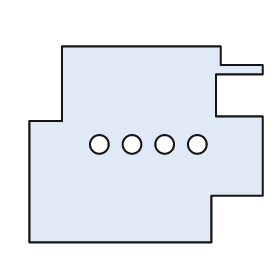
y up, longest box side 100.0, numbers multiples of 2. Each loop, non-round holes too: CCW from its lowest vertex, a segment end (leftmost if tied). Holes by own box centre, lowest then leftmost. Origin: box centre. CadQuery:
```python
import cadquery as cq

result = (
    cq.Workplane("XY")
    .moveTo(-50.0, -42.0)
    .lineTo(28.0, -42.0)
    .lineTo(28.0, -22.0)
    .lineTo(50.0, -22.0)
    .lineTo(50.0, 12.0)
    .lineTo(30.0, 12.0)
    .lineTo(30.0, 30.0)
    .lineTo(50.0, 30.0)
    .lineTo(50.0, 34.0)
    .lineTo(32.0, 34.0)
    .lineTo(32.0, 42.0)
    .lineTo(-36.0, 42.0)
    .lineTo(-36.0, 10.0)
    .lineTo(-50.0, 10.0)
    .close()
    .moveTo(-20.0, 0.0)
    .circle(4.0)
    .moveTo(-6.0, 0.0)
    .circle(4.0)
    .moveTo(8.0, 0.0)
    .circle(4.0)
    .moveTo(22.0, 0.0)
    .circle(4.0)
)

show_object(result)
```